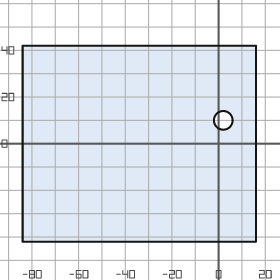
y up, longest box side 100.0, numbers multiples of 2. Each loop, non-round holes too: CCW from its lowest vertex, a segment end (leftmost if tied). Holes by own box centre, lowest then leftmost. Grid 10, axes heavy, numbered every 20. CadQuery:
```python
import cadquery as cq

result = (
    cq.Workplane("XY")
    .moveTo(-84.0, -42.0)
    .lineTo(16.0, -42.0)
    .lineTo(16.0, 42.0)
    .lineTo(-84.0, 42.0)
    .close()
    .moveTo(2.0, 10.0)
    .circle(4.0)
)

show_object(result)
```